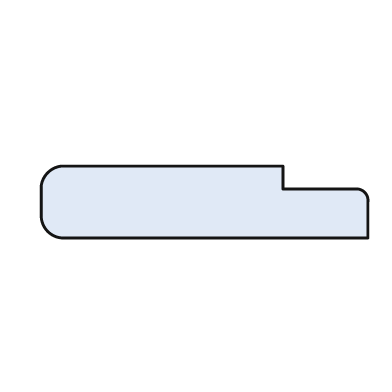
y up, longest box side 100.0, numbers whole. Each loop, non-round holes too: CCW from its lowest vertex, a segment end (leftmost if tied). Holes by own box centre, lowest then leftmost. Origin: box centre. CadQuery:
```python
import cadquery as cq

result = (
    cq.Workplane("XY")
    .moveTo(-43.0, -11.0)
    .lineTo(50.0, -11.0)
    .lineTo(50.0, 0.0)
    .threePointArc((49.0, 3.0), (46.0, 4.0))
    .lineTo(24.0, 4.0)
    .lineTo(24.0, 11.0)
    .lineTo(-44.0, 11.0)
    .threePointArc((-48.0, 9.0), (-50.0, 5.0))
    .lineTo(-50.0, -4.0)
    .threePointArc((-48.0, -9.0), (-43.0, -11.0))
    .close()
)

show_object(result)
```